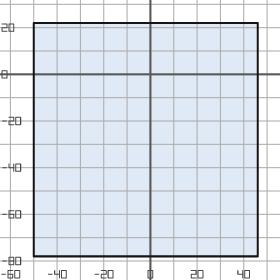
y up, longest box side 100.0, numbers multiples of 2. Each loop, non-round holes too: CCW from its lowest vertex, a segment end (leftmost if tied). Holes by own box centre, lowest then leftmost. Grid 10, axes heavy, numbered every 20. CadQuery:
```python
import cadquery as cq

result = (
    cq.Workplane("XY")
    .moveTo(-50.0, -78.0)
    .lineTo(46.0, -78.0)
    .lineTo(46.0, 22.0)
    .lineTo(-50.0, 22.0)
    .close()
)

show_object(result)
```